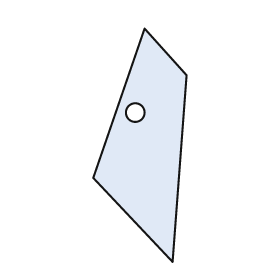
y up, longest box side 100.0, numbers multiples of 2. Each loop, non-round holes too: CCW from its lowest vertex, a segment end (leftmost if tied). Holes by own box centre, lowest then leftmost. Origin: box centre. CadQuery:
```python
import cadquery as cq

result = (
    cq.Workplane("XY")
    .moveTo(14.0, -50.0)
    .lineTo(20.0, 30.0)
    .lineTo(2.0, 50.0)
    .lineTo(-20.0, -14.0)
    .close()
    .moveTo(-2.0, 14.0)
    .circle(4.0)
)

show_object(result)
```